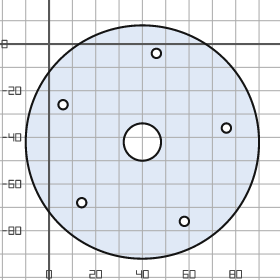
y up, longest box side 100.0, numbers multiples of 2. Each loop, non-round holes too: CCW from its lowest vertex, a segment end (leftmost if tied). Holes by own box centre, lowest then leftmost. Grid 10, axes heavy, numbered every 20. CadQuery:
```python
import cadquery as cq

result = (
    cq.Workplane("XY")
    .moveTo(40.0, -42.0)
    .circle(50.0)
    .moveTo(58.0, -76.0)
    .circle(2.0)
    .moveTo(14.0, -68.0)
    .circle(2.0)
    .moveTo(40.0, -42.0)
    .circle(8.0)
    .moveTo(76.0, -36.0)
    .circle(2.0)
    .moveTo(6.0, -26.0)
    .circle(2.0)
    .moveTo(46.0, -4.0)
    .circle(2.0)
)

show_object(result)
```